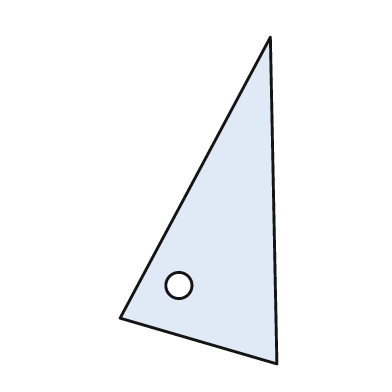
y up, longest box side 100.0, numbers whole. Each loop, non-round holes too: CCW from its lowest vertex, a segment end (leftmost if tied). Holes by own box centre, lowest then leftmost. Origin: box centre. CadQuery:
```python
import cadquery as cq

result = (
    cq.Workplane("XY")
    .moveTo(24.0, -50.0)
    .lineTo(22.0, 50.0)
    .lineTo(-24.0, -36.0)
    .close()
    .moveTo(-6.0, -26.0)
    .circle(4.0)
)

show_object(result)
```